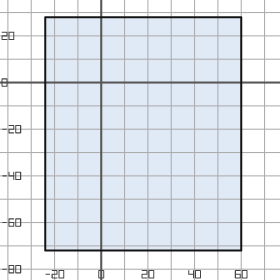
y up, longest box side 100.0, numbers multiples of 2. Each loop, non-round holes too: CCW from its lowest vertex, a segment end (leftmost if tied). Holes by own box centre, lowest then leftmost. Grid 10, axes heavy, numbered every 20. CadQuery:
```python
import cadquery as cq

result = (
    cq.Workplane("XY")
    .moveTo(-24.0, -72.0)
    .lineTo(60.0, -72.0)
    .lineTo(60.0, 28.0)
    .lineTo(-24.0, 28.0)
    .close()
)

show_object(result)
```